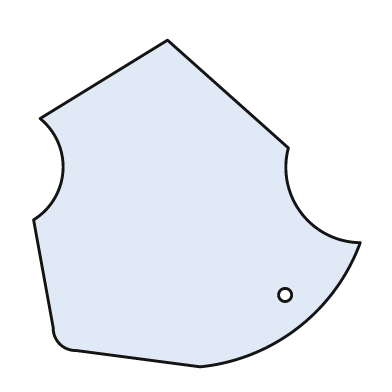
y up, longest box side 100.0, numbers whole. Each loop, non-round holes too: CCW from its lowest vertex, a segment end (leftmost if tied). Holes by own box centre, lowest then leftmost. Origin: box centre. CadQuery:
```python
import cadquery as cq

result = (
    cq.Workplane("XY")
    .moveTo(1.0, -50.0)
    .threePointArc((31.0, -38.0), (50.0, -12.0))
    .threePointArc((32.0, -3.0), (28.0, 17.0))
    .lineTo(-9.0, 50.0)
    .lineTo(-48.0, 26.0)
    .threePointArc((-41.0, 10.0), (-50.0, -5.0))
    .lineTo(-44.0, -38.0)
    .threePointArc((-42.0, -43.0), (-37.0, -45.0))
    .close()
    .moveTo(27.0, -28.0)
    .circle(2.0)
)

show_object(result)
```